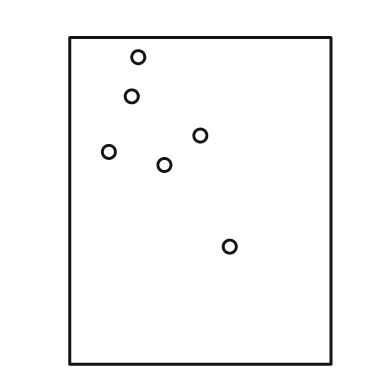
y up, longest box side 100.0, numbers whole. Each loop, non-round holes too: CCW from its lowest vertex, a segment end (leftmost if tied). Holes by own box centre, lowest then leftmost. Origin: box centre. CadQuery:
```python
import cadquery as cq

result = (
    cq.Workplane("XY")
    .moveTo(-40.0, -50.0)
    .lineTo(40.0, -50.0)
    .lineTo(40.0, 50.0)
    .lineTo(-40.0, 50.0)
    .close()
    .moveTo(9.0, -14.0)
    .circle(2.0)
    .moveTo(-11.0, 11.0)
    .circle(2.0)
    .moveTo(-28.0, 15.0)
    .circle(2.0)
    .moveTo(0.0, 20.0)
    .circle(2.0)
    .moveTo(-21.0, 32.0)
    .circle(2.0)
    .moveTo(-19.0, 44.0)
    .circle(2.0)
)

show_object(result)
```